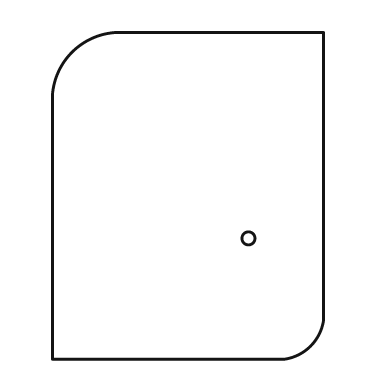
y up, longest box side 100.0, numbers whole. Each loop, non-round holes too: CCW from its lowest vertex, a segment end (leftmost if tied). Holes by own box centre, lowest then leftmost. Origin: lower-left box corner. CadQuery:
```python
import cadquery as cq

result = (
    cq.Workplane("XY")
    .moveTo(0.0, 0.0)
    .lineTo(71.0, 0.0)
    .threePointArc((79.0, 4.0), (83.0, 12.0))
    .lineTo(83.0, 100.0)
    .lineTo(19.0, 100.0)
    .threePointArc((6.0, 94.0), (0.0, 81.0))
    .close()
    .moveTo(60.0, 37.0)
    .circle(2.0)
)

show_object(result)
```